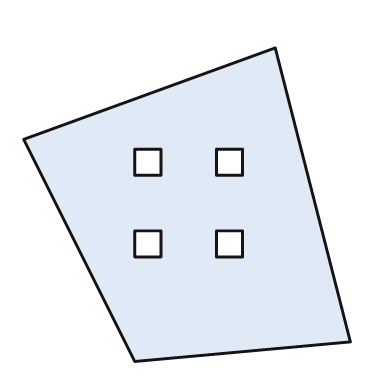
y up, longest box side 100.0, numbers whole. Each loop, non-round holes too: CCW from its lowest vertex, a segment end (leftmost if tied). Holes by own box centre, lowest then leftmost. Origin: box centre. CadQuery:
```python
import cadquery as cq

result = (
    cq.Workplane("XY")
    .moveTo(-16.0, -48.0)
    .lineTo(50.0, -42.0)
    .lineTo(27.0, 48.0)
    .lineTo(-50.0, 20.0)
    .close()
    .moveTo(-16.0, -16.0)
    .lineTo(-8.0, -16.0)
    .lineTo(-8.0, -8.0)
    .lineTo(-16.0, -8.0)
    .close()
    .moveTo(9.0, -16.0)
    .lineTo(17.0, -16.0)
    .lineTo(17.0, -8.0)
    .lineTo(9.0, -8.0)
    .close()
    .moveTo(-16.0, 9.0)
    .lineTo(-8.0, 9.0)
    .lineTo(-8.0, 17.0)
    .lineTo(-16.0, 17.0)
    .close()
    .moveTo(9.0, 9.0)
    .lineTo(17.0, 9.0)
    .lineTo(17.0, 17.0)
    .lineTo(9.0, 17.0)
    .close()
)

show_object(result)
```